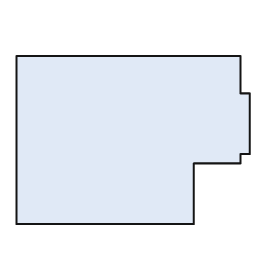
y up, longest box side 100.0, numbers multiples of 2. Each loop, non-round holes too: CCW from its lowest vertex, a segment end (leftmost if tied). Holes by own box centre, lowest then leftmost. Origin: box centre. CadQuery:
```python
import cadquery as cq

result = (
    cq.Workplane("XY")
    .moveTo(-50.0, -36.0)
    .lineTo(26.0, -36.0)
    .lineTo(26.0, -10.0)
    .lineTo(46.0, -10.0)
    .lineTo(46.0, -6.0)
    .lineTo(50.0, -6.0)
    .lineTo(50.0, 20.0)
    .lineTo(46.0, 20.0)
    .lineTo(46.0, 36.0)
    .lineTo(-50.0, 36.0)
    .close()
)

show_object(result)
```